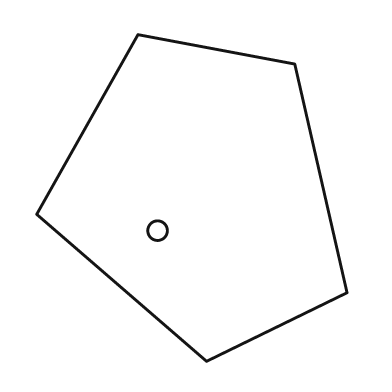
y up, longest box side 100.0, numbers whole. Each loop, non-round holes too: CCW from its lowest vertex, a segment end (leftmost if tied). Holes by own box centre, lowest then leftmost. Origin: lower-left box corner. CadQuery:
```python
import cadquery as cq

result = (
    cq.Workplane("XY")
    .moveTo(52.0, 0.0)
    .lineTo(95.0, 21.0)
    .lineTo(79.0, 91.0)
    .lineTo(31.0, 100.0)
    .lineTo(0.0, 45.0)
    .close()
    .moveTo(37.0, 40.0)
    .circle(3.0)
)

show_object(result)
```